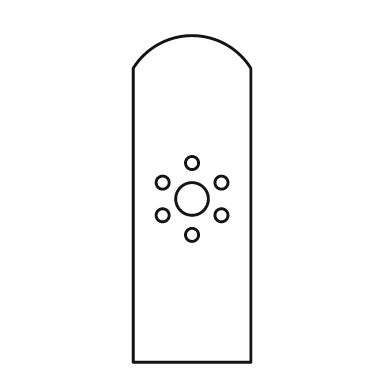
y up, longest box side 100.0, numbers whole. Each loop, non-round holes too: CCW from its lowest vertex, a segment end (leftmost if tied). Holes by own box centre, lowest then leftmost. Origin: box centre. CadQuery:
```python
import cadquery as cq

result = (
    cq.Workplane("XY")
    .moveTo(-18.0, -50.0)
    .lineTo(18.0, -50.0)
    .lineTo(18.0, 40.0)
    .threePointArc((0.0, 50.0), (-18.0, 40.0))
    .close()
    .moveTo(0.0, -11.0)
    .circle(2.0)
    .moveTo(-9.0, -5.0)
    .circle(2.0)
    .moveTo(9.0, -5.0)
    .circle(2.0)
    .moveTo(0.0, 0.0)
    .circle(5.0)
    .moveTo(-9.0, 5.0)
    .circle(2.0)
    .moveTo(9.0, 5.0)
    .circle(2.0)
    .moveTo(0.0, 11.0)
    .circle(2.0)
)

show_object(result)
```